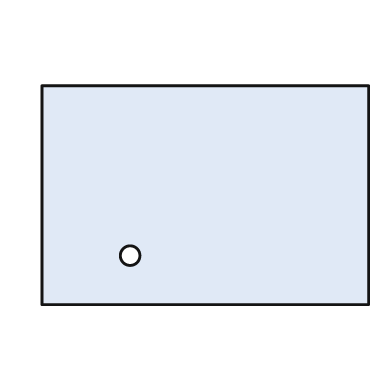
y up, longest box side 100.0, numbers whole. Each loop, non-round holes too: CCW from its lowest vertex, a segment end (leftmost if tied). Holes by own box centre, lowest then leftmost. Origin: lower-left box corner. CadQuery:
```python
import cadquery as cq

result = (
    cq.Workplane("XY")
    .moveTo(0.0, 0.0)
    .lineTo(100.0, 0.0)
    .lineTo(100.0, 67.0)
    .lineTo(0.0, 67.0)
    .close()
    .moveTo(27.0, 15.0)
    .circle(3.0)
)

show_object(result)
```